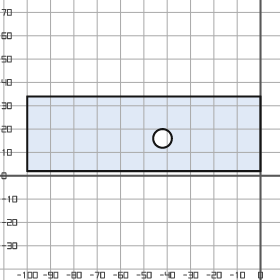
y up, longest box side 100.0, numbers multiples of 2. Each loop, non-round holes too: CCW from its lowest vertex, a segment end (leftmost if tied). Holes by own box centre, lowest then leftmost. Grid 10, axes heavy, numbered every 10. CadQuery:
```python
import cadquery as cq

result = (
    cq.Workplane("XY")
    .moveTo(-100.0, 2.0)
    .lineTo(0.0, 2.0)
    .lineTo(0.0, 34.0)
    .lineTo(-100.0, 34.0)
    .close()
    .moveTo(-42.0, 16.0)
    .circle(4.0)
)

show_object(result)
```